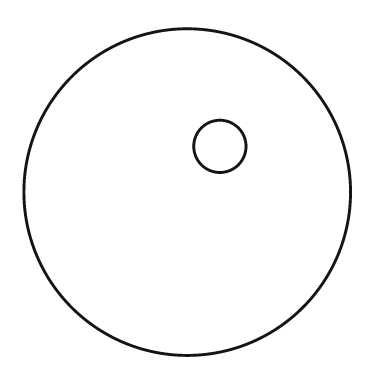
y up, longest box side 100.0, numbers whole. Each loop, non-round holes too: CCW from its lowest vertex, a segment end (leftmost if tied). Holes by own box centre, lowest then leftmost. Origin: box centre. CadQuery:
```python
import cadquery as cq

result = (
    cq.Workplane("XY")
    .moveTo(0.0, 0.0)
    .circle(50.0)
    .moveTo(10.0, 14.0)
    .circle(8.0)
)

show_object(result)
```